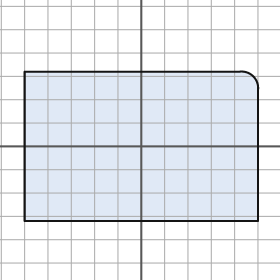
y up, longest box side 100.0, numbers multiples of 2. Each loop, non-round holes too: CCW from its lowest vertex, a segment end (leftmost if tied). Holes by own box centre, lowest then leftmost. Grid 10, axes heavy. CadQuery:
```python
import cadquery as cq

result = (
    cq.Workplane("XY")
    .moveTo(-50.0, -32.0)
    .lineTo(50.0, -32.0)
    .lineTo(50.0, 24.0)
    .threePointArc((48.0, 30.0), (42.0, 32.0))
    .lineTo(-50.0, 32.0)
    .close()
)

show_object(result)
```